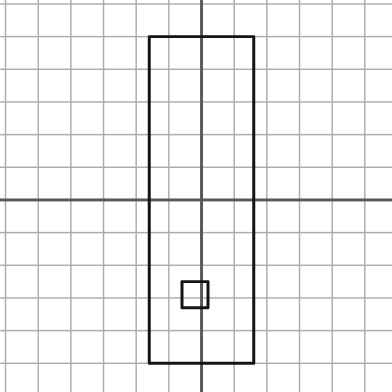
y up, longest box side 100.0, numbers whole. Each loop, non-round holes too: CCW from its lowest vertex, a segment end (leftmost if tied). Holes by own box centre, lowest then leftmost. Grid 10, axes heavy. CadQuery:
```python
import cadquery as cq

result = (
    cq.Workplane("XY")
    .moveTo(-16.0, -50.0)
    .lineTo(16.0, -50.0)
    .lineTo(16.0, 50.0)
    .lineTo(-16.0, 50.0)
    .close()
    .moveTo(-6.0, -33.0)
    .lineTo(2.0, -33.0)
    .lineTo(2.0, -25.0)
    .lineTo(-6.0, -25.0)
    .close()
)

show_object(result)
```